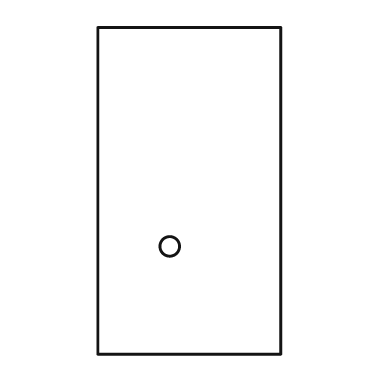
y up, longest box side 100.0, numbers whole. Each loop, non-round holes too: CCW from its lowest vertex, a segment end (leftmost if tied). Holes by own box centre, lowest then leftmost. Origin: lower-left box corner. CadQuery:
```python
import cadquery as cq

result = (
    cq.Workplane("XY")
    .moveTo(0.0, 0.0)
    .lineTo(56.0, 0.0)
    .lineTo(56.0, 100.0)
    .lineTo(0.0, 100.0)
    .close()
    .moveTo(22.0, 33.0)
    .circle(3.0)
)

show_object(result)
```